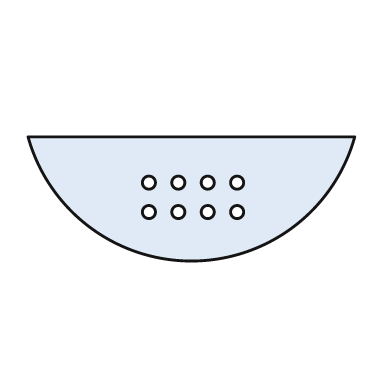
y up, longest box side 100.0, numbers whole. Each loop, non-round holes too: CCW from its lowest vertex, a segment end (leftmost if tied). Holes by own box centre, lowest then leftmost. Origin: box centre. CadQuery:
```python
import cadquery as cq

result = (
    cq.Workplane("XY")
    .moveTo(-50.0, 19.0)
    .threePointArc((0.0, -19.0), (50.0, 19.0))
    .close()
    .moveTo(-13.0, -4.0)
    .circle(2.0)
    .moveTo(-4.0, -4.0)
    .circle(2.0)
    .moveTo(5.0, -4.0)
    .circle(2.0)
    .moveTo(14.0, -4.0)
    .circle(2.0)
    .moveTo(-13.0, 5.0)
    .circle(2.0)
    .moveTo(-4.0, 5.0)
    .circle(2.0)
    .moveTo(5.0, 5.0)
    .circle(2.0)
    .moveTo(14.0, 5.0)
    .circle(2.0)
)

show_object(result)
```